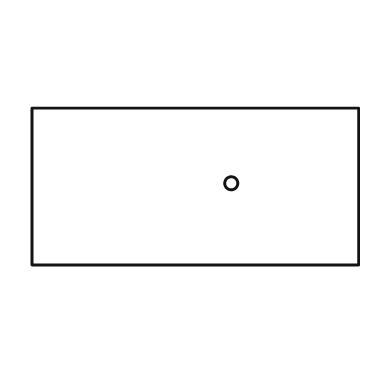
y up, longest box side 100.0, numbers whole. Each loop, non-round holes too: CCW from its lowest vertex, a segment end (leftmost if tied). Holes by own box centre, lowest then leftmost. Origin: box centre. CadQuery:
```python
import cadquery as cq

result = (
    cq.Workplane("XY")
    .moveTo(-50.0, -24.0)
    .lineTo(50.0, -24.0)
    .lineTo(50.0, 24.0)
    .lineTo(-50.0, 24.0)
    .close()
    .moveTo(11.0, 1.0)
    .circle(2.0)
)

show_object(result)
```